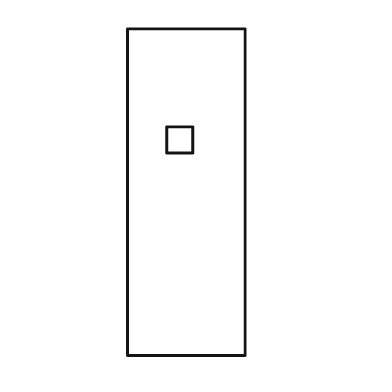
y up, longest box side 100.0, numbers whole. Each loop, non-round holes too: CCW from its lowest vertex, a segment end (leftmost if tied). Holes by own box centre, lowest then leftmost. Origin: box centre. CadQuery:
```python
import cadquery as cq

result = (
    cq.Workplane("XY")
    .moveTo(-18.0, -50.0)
    .lineTo(18.0, -50.0)
    .lineTo(18.0, 50.0)
    .lineTo(-18.0, 50.0)
    .close()
    .moveTo(-6.0, 12.0)
    .lineTo(2.0, 12.0)
    .lineTo(2.0, 20.0)
    .lineTo(-6.0, 20.0)
    .close()
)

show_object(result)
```